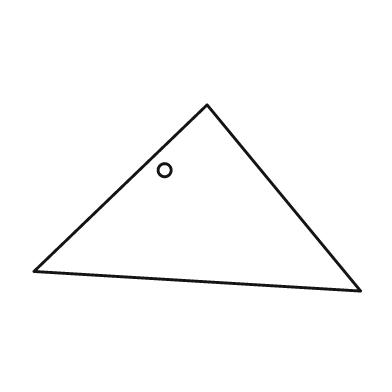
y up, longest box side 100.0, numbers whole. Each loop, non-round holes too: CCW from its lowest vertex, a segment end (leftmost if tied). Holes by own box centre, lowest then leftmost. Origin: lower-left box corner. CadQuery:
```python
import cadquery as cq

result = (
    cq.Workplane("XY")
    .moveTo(100.0, 0.0)
    .lineTo(53.0, 57.0)
    .lineTo(0.0, 6.0)
    .close()
    .moveTo(40.0, 37.0)
    .circle(2.0)
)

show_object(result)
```